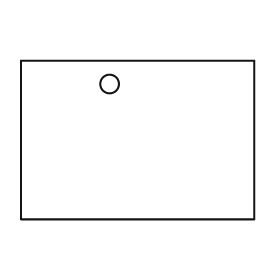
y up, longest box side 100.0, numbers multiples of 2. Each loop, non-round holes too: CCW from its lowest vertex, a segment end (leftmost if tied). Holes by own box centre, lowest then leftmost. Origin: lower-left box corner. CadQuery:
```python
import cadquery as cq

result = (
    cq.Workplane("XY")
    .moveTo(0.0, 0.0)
    .lineTo(100.0, 0.0)
    .lineTo(100.0, 68.0)
    .lineTo(0.0, 68.0)
    .close()
    .moveTo(38.0, 58.0)
    .circle(4.0)
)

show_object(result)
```